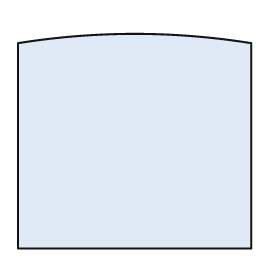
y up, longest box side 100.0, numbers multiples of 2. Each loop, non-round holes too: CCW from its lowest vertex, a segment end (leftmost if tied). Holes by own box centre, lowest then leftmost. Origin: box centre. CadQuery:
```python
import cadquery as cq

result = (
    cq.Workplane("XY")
    .moveTo(-50.0, -46.0)
    .lineTo(50.0, -46.0)
    .lineTo(50.0, 42.0)
    .threePointArc((0.0, 46.0), (-50.0, 42.0))
    .close()
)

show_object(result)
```